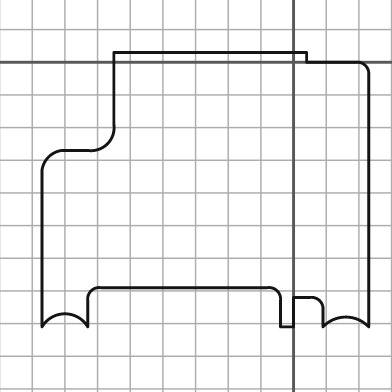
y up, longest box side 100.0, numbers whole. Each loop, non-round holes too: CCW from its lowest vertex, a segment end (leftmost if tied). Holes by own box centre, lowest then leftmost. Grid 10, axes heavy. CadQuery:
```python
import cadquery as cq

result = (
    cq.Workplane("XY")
    .moveTo(-77.0, -81.0)
    .threePointArc((-70.0, -77.0), (-63.0, -81.0))
    .lineTo(-63.0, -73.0)
    .threePointArc((-62.0, -70.0), (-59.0, -69.0))
    .lineTo(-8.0, -69.0)
    .threePointArc((-5.0, -70.0), (-4.0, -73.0))
    .lineTo(-4.0, -81.0)
    .lineTo(0.0, -81.0)
    .lineTo(0.0, -72.0)
    .lineTo(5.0, -72.0)
    .threePointArc((8.0, -73.0), (9.0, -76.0))
    .lineTo(9.0, -81.0)
    .threePointArc((16.0, -78.0), (23.0, -81.0))
    .lineTo(23.0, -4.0)
    .threePointArc((22.0, -1.0), (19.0, 0.0))
    .lineTo(4.0, 0.0)
    .lineTo(4.0, 3.0)
    .lineTo(-55.0, 3.0)
    .lineTo(-55.0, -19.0)
    .threePointArc((-57.0, -25.0), (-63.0, -27.0))
    .lineTo(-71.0, -27.0)
    .threePointArc((-75.0, -29.0), (-77.0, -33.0))
    .close()
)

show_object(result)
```